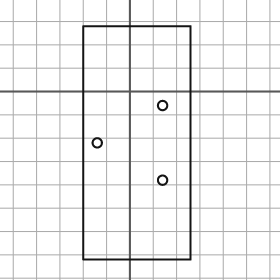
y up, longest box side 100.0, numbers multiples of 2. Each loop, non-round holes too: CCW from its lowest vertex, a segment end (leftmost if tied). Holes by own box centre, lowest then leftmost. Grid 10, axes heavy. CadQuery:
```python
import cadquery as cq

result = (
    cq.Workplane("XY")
    .moveTo(-20.0, -72.0)
    .lineTo(26.0, -72.0)
    .lineTo(26.0, 28.0)
    .lineTo(-20.0, 28.0)
    .close()
    .moveTo(14.0, -38.0)
    .circle(2.0)
    .moveTo(-14.0, -22.0)
    .circle(2.0)
    .moveTo(14.0, -6.0)
    .circle(2.0)
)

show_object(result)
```